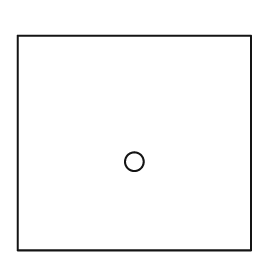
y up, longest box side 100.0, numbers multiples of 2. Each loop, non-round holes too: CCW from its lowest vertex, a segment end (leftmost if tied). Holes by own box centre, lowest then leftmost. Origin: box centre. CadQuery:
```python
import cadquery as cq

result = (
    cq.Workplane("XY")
    .moveTo(-50.0, -46.0)
    .lineTo(50.0, -46.0)
    .lineTo(50.0, 46.0)
    .lineTo(-50.0, 46.0)
    .close()
    .moveTo(0.0, -8.0)
    .circle(4.0)
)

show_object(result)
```